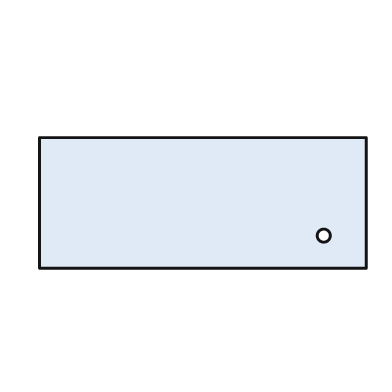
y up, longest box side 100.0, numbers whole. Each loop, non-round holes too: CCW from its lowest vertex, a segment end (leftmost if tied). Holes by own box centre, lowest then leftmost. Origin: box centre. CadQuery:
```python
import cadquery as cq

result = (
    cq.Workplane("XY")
    .moveTo(-50.0, -20.0)
    .lineTo(50.0, -20.0)
    .lineTo(50.0, 20.0)
    .lineTo(-50.0, 20.0)
    .close()
    .moveTo(37.0, -10.0)
    .circle(2.0)
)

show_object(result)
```